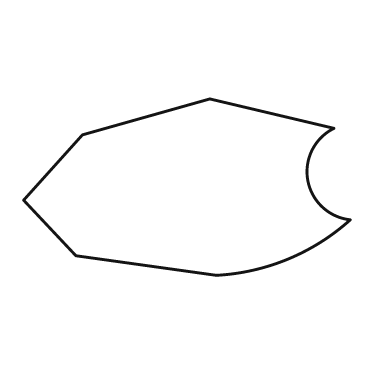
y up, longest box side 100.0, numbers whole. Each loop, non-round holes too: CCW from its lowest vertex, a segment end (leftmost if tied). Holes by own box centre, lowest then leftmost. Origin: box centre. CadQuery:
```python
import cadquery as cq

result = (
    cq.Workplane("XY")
    .moveTo(9.0, -27.0)
    .threePointArc((31.0, -22.0), (50.0, -10.0))
    .threePointArc((37.0, 2.0), (45.0, 18.0))
    .lineTo(7.0, 27.0)
    .lineTo(-32.0, 16.0)
    .lineTo(-50.0, -4.0)
    .lineTo(-34.0, -21.0)
    .close()
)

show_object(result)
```